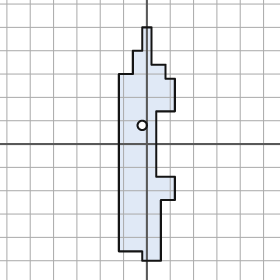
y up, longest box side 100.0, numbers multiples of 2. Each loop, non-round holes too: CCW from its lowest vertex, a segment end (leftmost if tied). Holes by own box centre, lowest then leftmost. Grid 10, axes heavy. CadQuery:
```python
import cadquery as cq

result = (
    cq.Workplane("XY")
    .moveTo(-2.0, -50.0)
    .lineTo(6.0, -50.0)
    .lineTo(6.0, -24.0)
    .lineTo(12.0, -24.0)
    .lineTo(12.0, -14.0)
    .lineTo(4.0, -14.0)
    .lineTo(4.0, 14.0)
    .lineTo(12.0, 14.0)
    .lineTo(12.0, 28.0)
    .lineTo(8.0, 28.0)
    .lineTo(8.0, 34.0)
    .lineTo(2.0, 34.0)
    .lineTo(2.0, 50.0)
    .lineTo(-2.0, 50.0)
    .lineTo(-2.0, 40.0)
    .lineTo(-6.0, 40.0)
    .lineTo(-6.0, 30.0)
    .lineTo(-12.0, 30.0)
    .lineTo(-12.0, -46.0)
    .lineTo(-2.0, -46.0)
    .close()
    .moveTo(-2.0, 8.0)
    .circle(2.0)
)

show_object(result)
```